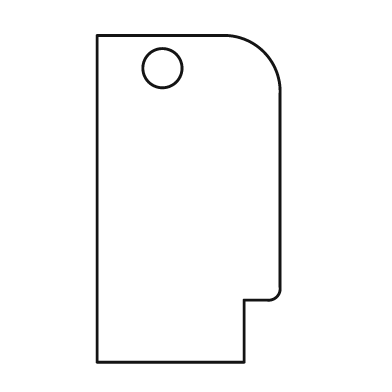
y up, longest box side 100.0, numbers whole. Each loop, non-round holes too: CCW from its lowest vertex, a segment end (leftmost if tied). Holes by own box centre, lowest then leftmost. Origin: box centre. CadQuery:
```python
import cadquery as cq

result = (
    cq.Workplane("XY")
    .moveTo(-28.0, -50.0)
    .lineTo(17.0, -50.0)
    .lineTo(17.0, -31.0)
    .lineTo(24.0, -31.0)
    .threePointArc((27.0, -30.0), (28.0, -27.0))
    .lineTo(28.0, 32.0)
    .threePointArc((23.0, 45.0), (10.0, 50.0))
    .lineTo(-28.0, 50.0)
    .close()
    .moveTo(-8.0, 40.0)
    .circle(6.0)
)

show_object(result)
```